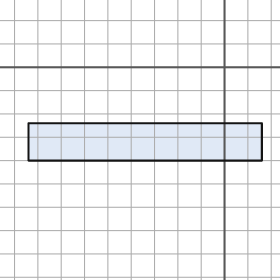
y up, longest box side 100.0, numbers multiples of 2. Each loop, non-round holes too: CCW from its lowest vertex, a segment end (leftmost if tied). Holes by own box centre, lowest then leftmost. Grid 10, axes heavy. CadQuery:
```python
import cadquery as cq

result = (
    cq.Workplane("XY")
    .moveTo(-84.0, -40.0)
    .lineTo(16.0, -40.0)
    .lineTo(16.0, -24.0)
    .lineTo(-84.0, -24.0)
    .close()
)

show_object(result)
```